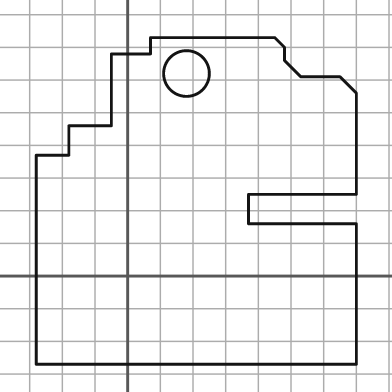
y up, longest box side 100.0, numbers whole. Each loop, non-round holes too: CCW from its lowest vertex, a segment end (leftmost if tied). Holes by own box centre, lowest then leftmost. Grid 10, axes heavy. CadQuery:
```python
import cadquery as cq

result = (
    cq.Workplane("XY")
    .moveTo(-28.0, -27.0)
    .lineTo(70.0, -27.0)
    .lineTo(70.0, 16.0)
    .lineTo(37.0, 16.0)
    .lineTo(37.0, 25.0)
    .lineTo(70.0, 25.0)
    .lineTo(70.0, 56.0)
    .lineTo(65.0, 61.0)
    .lineTo(53.0, 61.0)
    .lineTo(48.0, 66.0)
    .lineTo(48.0, 70.0)
    .lineTo(45.0, 73.0)
    .lineTo(7.0, 73.0)
    .lineTo(7.0, 68.0)
    .lineTo(-5.0, 68.0)
    .lineTo(-5.0, 46.0)
    .lineTo(-18.0, 46.0)
    .lineTo(-18.0, 37.0)
    .lineTo(-28.0, 37.0)
    .close()
    .moveTo(18.0, 62.0)
    .circle(7.0)
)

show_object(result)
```